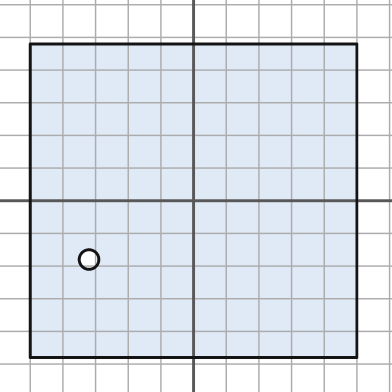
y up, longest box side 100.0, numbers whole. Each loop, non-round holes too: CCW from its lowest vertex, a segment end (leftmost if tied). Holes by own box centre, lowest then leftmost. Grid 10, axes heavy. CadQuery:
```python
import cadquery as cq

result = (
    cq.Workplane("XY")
    .moveTo(-50.0, -48.0)
    .lineTo(50.0, -48.0)
    .lineTo(50.0, 48.0)
    .lineTo(-50.0, 48.0)
    .close()
    .moveTo(-32.0, -18.0)
    .circle(3.0)
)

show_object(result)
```